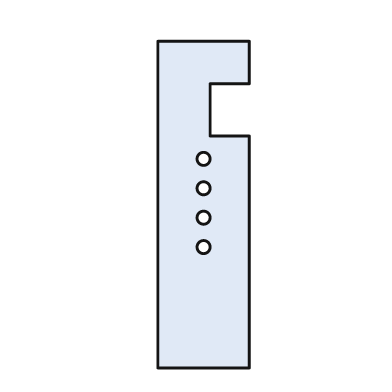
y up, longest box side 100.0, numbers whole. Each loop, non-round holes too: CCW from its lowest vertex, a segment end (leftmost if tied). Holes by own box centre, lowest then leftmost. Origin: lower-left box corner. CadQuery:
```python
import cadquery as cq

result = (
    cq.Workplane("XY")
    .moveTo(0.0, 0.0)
    .lineTo(28.0, 0.0)
    .lineTo(28.0, 71.0)
    .lineTo(16.0, 71.0)
    .lineTo(16.0, 87.0)
    .lineTo(28.0, 87.0)
    .lineTo(28.0, 100.0)
    .lineTo(0.0, 100.0)
    .close()
    .moveTo(14.0, 37.0)
    .circle(2.0)
    .moveTo(14.0, 46.0)
    .circle(2.0)
    .moveTo(14.0, 55.0)
    .circle(2.0)
    .moveTo(14.0, 64.0)
    .circle(2.0)
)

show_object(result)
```